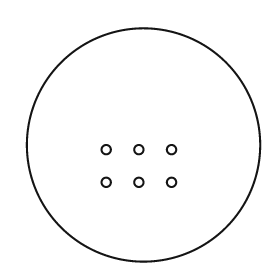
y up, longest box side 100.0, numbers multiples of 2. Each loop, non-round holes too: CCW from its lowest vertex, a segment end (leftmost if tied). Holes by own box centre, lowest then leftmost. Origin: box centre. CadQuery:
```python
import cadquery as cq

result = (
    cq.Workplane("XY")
    .moveTo(0.0, 0.0)
    .circle(50.0)
    .moveTo(-16.0, -16.0)
    .circle(2.0)
    .moveTo(-2.0, -16.0)
    .circle(2.0)
    .moveTo(12.0, -16.0)
    .circle(2.0)
    .moveTo(-16.0, -2.0)
    .circle(2.0)
    .moveTo(-2.0, -2.0)
    .circle(2.0)
    .moveTo(12.0, -2.0)
    .circle(2.0)
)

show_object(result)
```